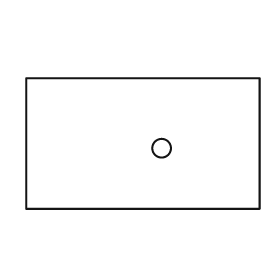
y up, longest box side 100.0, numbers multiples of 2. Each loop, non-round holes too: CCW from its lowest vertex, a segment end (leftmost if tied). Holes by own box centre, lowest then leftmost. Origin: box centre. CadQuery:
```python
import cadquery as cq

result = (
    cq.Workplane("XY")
    .moveTo(-50.0, -28.0)
    .lineTo(50.0, -28.0)
    .lineTo(50.0, 28.0)
    .lineTo(-50.0, 28.0)
    .close()
    .moveTo(8.0, -2.0)
    .circle(4.0)
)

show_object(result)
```